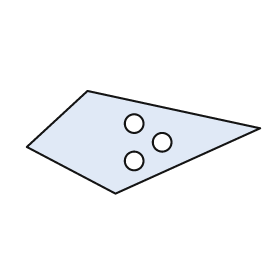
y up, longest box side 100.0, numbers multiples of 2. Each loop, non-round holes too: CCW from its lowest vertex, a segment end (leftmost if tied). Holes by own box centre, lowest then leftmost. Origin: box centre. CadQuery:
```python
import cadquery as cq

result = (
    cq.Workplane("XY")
    .moveTo(-12.0, -22.0)
    .lineTo(50.0, 6.0)
    .lineTo(-24.0, 22.0)
    .lineTo(-50.0, -2.0)
    .close()
    .moveTo(-4.0, -8.0)
    .circle(4.0)
    .moveTo(8.0, 0.0)
    .circle(4.0)
    .moveTo(-4.0, 8.0)
    .circle(4.0)
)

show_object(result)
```